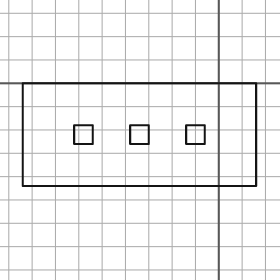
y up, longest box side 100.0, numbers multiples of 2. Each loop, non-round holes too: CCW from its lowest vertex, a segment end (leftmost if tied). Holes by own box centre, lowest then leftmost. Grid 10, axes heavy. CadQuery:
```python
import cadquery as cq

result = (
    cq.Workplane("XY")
    .moveTo(-84.0, -44.0)
    .lineTo(16.0, -44.0)
    .lineTo(16.0, 0.0)
    .lineTo(-84.0, 0.0)
    .close()
    .moveTo(-62.0, -26.0)
    .lineTo(-54.0, -26.0)
    .lineTo(-54.0, -18.0)
    .lineTo(-62.0, -18.0)
    .close()
    .moveTo(-38.0, -26.0)
    .lineTo(-30.0, -26.0)
    .lineTo(-30.0, -18.0)
    .lineTo(-38.0, -18.0)
    .close()
    .moveTo(-14.0, -26.0)
    .lineTo(-6.0, -26.0)
    .lineTo(-6.0, -18.0)
    .lineTo(-14.0, -18.0)
    .close()
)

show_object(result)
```